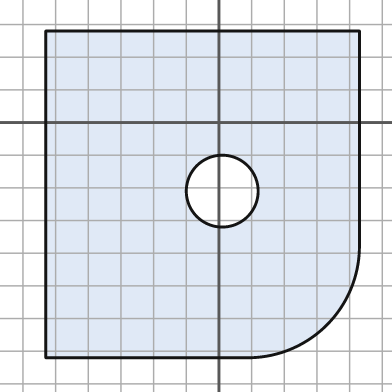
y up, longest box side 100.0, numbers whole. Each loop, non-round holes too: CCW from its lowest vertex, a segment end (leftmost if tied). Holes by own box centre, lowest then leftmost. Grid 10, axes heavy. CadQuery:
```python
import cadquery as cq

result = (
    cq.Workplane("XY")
    .moveTo(-53.0, -72.0)
    .lineTo(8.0, -72.0)
    .threePointArc((33.0, -62.0), (43.0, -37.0))
    .lineTo(43.0, 28.0)
    .lineTo(-53.0, 28.0)
    .close()
    .moveTo(1.0, -21.0)
    .circle(11.0)
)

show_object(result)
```